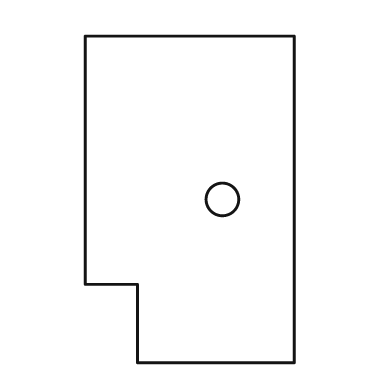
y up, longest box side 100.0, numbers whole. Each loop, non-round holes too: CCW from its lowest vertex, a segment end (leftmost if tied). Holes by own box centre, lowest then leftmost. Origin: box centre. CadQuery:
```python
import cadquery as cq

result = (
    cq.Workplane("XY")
    .moveTo(-16.0, -50.0)
    .lineTo(32.0, -50.0)
    .lineTo(32.0, 50.0)
    .lineTo(-32.0, 50.0)
    .lineTo(-32.0, -26.0)
    .lineTo(-16.0, -26.0)
    .close()
    .moveTo(10.0, 0.0)
    .circle(5.0)
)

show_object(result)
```